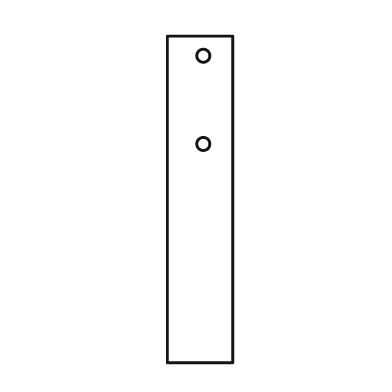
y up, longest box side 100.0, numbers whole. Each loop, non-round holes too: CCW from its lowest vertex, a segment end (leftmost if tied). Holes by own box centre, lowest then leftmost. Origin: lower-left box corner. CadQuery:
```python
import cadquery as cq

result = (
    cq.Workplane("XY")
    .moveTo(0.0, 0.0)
    .lineTo(20.0, 0.0)
    .lineTo(20.0, 100.0)
    .lineTo(0.0, 100.0)
    .close()
    .moveTo(11.0, 67.0)
    .circle(2.0)
    .moveTo(11.0, 94.0)
    .circle(2.0)
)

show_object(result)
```